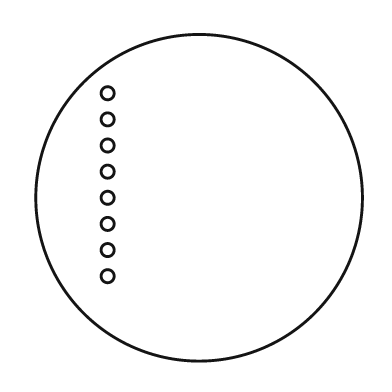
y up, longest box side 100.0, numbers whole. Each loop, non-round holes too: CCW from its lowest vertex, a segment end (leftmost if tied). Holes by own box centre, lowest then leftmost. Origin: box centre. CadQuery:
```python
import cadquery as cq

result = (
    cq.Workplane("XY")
    .moveTo(0.0, 0.0)
    .circle(50.0)
    .moveTo(-28.0, -24.0)
    .circle(2.0)
    .moveTo(-28.0, -16.0)
    .circle(2.0)
    .moveTo(-28.0, -8.0)
    .circle(2.0)
    .moveTo(-28.0, 0.0)
    .circle(2.0)
    .moveTo(-28.0, 8.0)
    .circle(2.0)
    .moveTo(-28.0, 16.0)
    .circle(2.0)
    .moveTo(-28.0, 24.0)
    .circle(2.0)
    .moveTo(-28.0, 32.0)
    .circle(2.0)
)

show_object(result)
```